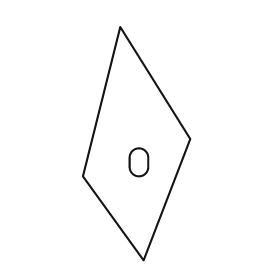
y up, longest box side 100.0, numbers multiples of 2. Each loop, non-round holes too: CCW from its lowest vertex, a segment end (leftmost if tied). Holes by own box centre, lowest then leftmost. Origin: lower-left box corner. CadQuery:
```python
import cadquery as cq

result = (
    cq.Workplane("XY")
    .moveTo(26.0, 0.0)
    .lineTo(46.0, 52.0)
    .lineTo(16.0, 100.0)
    .lineTo(0.0, 36.0)
    .close()
    .moveTo(20.0, 40.0)
    .threePointArc((24.0, 36.0), (28.0, 40.0))
    .lineTo(28.0, 44.0)
    .threePointArc((24.0, 48.0), (20.0, 44.0))
    .close()
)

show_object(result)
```